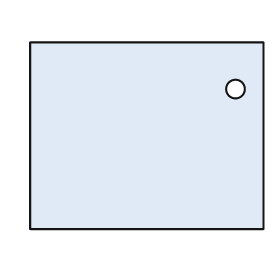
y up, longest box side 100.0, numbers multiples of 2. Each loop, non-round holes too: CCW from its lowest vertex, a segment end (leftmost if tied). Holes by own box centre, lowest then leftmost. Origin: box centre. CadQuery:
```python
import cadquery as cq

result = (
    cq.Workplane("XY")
    .moveTo(-50.0, -40.0)
    .lineTo(50.0, -40.0)
    .lineTo(50.0, 40.0)
    .lineTo(-50.0, 40.0)
    .close()
    .moveTo(38.0, 20.0)
    .circle(4.0)
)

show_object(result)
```